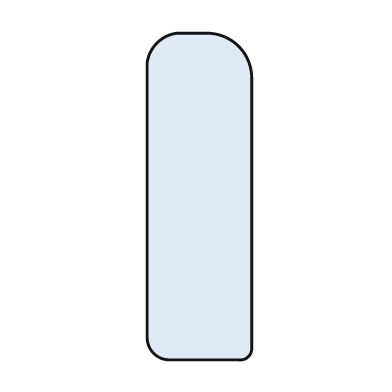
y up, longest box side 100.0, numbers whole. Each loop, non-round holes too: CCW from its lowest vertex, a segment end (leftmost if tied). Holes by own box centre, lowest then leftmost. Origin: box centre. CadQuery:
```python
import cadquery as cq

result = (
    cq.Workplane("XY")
    .moveTo(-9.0, -50.0)
    .lineTo(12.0, -50.0)
    .threePointArc((15.0, -49.0), (16.0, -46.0))
    .lineTo(16.0, 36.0)
    .threePointArc((12.0, 46.0), (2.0, 50.0))
    .lineTo(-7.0, 50.0)
    .threePointArc((-13.0, 47.0), (-16.0, 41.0))
    .lineTo(-16.0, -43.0)
    .threePointArc((-14.0, -48.0), (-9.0, -50.0))
    .close()
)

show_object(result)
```